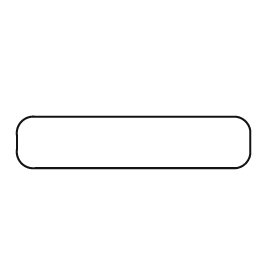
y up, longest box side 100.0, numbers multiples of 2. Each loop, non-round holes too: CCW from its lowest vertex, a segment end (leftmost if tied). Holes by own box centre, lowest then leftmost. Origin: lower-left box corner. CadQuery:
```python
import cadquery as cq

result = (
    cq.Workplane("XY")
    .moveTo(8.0, 0.0)
    .lineTo(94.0, 0.0)
    .threePointArc((98.0, 2.0), (100.0, 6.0))
    .lineTo(100.0, 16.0)
    .threePointArc((98.0, 20.0), (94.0, 22.0))
    .lineTo(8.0, 22.0)
    .threePointArc((2.0, 20.0), (0.0, 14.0))
    .lineTo(0.0, 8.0)
    .threePointArc((2.0, 2.0), (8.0, 0.0))
    .close()
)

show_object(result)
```